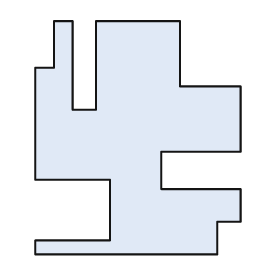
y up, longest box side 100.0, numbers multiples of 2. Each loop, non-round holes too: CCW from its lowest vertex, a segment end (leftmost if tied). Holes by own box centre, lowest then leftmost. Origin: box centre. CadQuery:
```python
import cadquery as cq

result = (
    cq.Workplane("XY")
    .moveTo(-44.0, -50.0)
    .lineTo(34.0, -50.0)
    .lineTo(34.0, -36.0)
    .lineTo(44.0, -36.0)
    .lineTo(44.0, -22.0)
    .lineTo(10.0, -22.0)
    .lineTo(10.0, -6.0)
    .lineTo(44.0, -6.0)
    .lineTo(44.0, 22.0)
    .lineTo(18.0, 22.0)
    .lineTo(18.0, 50.0)
    .lineTo(-18.0, 50.0)
    .lineTo(-18.0, 12.0)
    .lineTo(-28.0, 12.0)
    .lineTo(-28.0, 50.0)
    .lineTo(-36.0, 50.0)
    .lineTo(-36.0, 30.0)
    .lineTo(-44.0, 30.0)
    .lineTo(-44.0, -18.0)
    .lineTo(-12.0, -18.0)
    .lineTo(-12.0, -44.0)
    .lineTo(-44.0, -44.0)
    .close()
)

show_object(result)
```